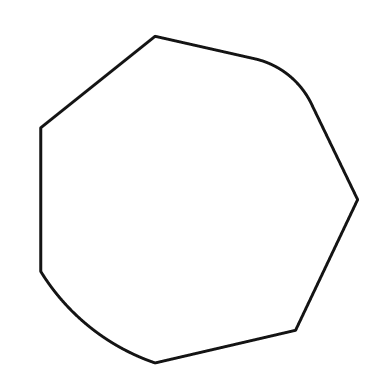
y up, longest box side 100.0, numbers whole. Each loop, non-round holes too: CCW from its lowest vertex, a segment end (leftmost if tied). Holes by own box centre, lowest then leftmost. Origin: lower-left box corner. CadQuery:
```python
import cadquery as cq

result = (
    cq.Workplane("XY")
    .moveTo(35.0, 0.0)
    .lineTo(78.0, 10.0)
    .lineTo(97.0, 50.0)
    .lineTo(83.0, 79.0)
    .threePointArc((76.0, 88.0), (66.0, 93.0))
    .lineTo(35.0, 100.0)
    .lineTo(0.0, 72.0)
    .lineTo(0.0, 28.0)
    .threePointArc((15.0, 11.0), (35.0, 0.0))
    .close()
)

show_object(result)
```